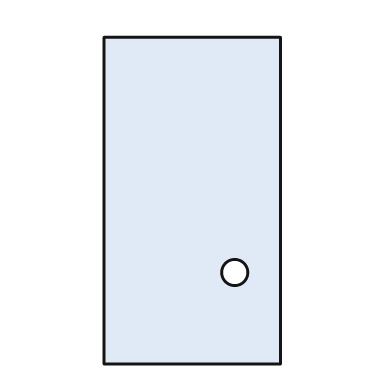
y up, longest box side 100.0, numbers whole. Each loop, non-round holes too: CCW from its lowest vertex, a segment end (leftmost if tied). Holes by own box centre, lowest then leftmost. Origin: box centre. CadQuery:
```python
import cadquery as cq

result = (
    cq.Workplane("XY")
    .moveTo(-27.0, -50.0)
    .lineTo(27.0, -50.0)
    .lineTo(27.0, 50.0)
    .lineTo(-27.0, 50.0)
    .close()
    .moveTo(13.0, -22.0)
    .circle(4.0)
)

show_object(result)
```